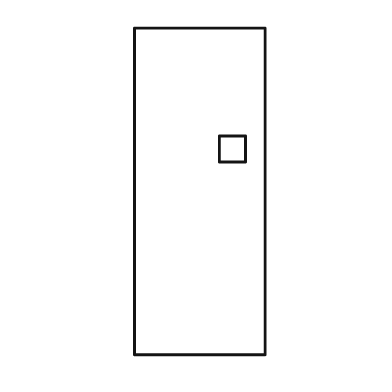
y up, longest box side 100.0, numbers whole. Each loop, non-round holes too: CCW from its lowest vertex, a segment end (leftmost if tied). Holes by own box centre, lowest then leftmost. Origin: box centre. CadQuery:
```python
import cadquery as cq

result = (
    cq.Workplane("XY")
    .moveTo(-20.0, -50.0)
    .lineTo(20.0, -50.0)
    .lineTo(20.0, 50.0)
    .lineTo(-20.0, 50.0)
    .close()
    .moveTo(6.0, 9.0)
    .lineTo(14.0, 9.0)
    .lineTo(14.0, 17.0)
    .lineTo(6.0, 17.0)
    .close()
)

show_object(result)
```